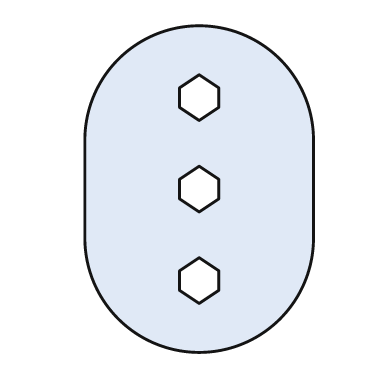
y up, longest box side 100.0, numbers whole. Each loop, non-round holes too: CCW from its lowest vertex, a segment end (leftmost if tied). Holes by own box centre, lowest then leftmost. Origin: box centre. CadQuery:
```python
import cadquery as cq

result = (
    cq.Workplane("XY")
    .moveTo(-35.0, -15.0)
    .threePointArc((0.0, -50.0), (35.0, -15.0))
    .lineTo(35.0, 15.0)
    .threePointArc((0.0, 50.0), (-35.0, 15.0))
    .close()
    .moveTo(0.0, -35.0)
    .lineTo(6.0, -31.0)
    .lineTo(6.0, -25.0)
    .lineTo(0.0, -21.0)
    .lineTo(-6.0, -25.0)
    .lineTo(-6.0, -31.0)
    .close()
    .moveTo(0.0, -7.0)
    .lineTo(6.0, -3.0)
    .lineTo(6.0, 3.0)
    .lineTo(0.0, 7.0)
    .lineTo(-6.0, 3.0)
    .lineTo(-6.0, -3.0)
    .close()
    .moveTo(0.0, 21.0)
    .lineTo(6.0, 25.0)
    .lineTo(6.0, 31.0)
    .lineTo(0.0, 35.0)
    .lineTo(-6.0, 31.0)
    .lineTo(-6.0, 25.0)
    .close()
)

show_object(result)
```